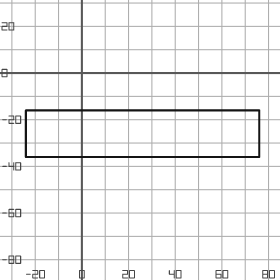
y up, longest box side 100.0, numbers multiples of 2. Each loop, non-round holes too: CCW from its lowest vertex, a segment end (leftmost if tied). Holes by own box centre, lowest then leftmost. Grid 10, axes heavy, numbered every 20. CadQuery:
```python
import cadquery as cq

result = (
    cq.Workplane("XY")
    .moveTo(-24.0, -36.0)
    .lineTo(76.0, -36.0)
    .lineTo(76.0, -16.0)
    .lineTo(-24.0, -16.0)
    .close()
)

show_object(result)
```